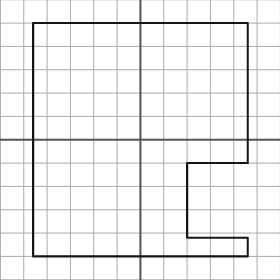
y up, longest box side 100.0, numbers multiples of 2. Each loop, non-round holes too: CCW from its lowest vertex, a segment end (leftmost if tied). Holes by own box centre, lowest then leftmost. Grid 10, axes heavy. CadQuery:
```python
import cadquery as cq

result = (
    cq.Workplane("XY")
    .moveTo(-46.0, -50.0)
    .lineTo(46.0, -50.0)
    .lineTo(46.0, -42.0)
    .lineTo(20.0, -42.0)
    .lineTo(20.0, -10.0)
    .lineTo(46.0, -10.0)
    .lineTo(46.0, 50.0)
    .lineTo(-46.0, 50.0)
    .close()
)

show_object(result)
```